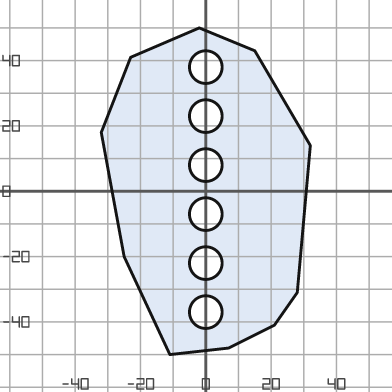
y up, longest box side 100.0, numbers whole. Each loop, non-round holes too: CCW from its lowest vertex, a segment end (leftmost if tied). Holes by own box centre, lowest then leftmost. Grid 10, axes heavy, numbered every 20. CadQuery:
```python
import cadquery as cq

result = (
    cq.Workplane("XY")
    .moveTo(-11.0, -50.0)
    .lineTo(7.0, -48.0)
    .lineTo(21.0, -41.0)
    .lineTo(28.0, -31.0)
    .lineTo(32.0, 14.0)
    .lineTo(15.0, 43.0)
    .lineTo(-2.0, 50.0)
    .lineTo(-23.0, 41.0)
    .lineTo(-32.0, 18.0)
    .lineTo(-25.0, -20.0)
    .close()
    .moveTo(0.0, -37.0)
    .circle(5.0)
    .moveTo(0.0, -22.0)
    .circle(5.0)
    .moveTo(0.0, -7.0)
    .circle(5.0)
    .moveTo(0.0, 8.0)
    .circle(5.0)
    .moveTo(0.0, 23.0)
    .circle(5.0)
    .moveTo(0.0, 38.0)
    .circle(5.0)
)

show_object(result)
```